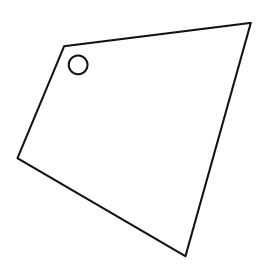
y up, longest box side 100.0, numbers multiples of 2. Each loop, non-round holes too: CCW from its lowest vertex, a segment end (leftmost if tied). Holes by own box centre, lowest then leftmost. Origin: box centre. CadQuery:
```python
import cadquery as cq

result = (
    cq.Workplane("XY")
    .moveTo(22.0, -50.0)
    .lineTo(50.0, 50.0)
    .lineTo(-30.0, 40.0)
    .lineTo(-50.0, -8.0)
    .close()
    .moveTo(-24.0, 32.0)
    .circle(4.0)
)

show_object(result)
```